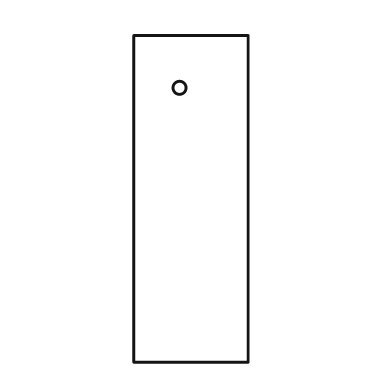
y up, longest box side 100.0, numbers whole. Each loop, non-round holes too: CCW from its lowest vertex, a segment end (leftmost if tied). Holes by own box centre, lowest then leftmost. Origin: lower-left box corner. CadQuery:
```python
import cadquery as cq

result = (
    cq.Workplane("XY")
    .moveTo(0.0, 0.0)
    .lineTo(35.0, 0.0)
    .lineTo(35.0, 100.0)
    .lineTo(0.0, 100.0)
    .close()
    .moveTo(14.0, 84.0)
    .circle(2.0)
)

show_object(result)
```